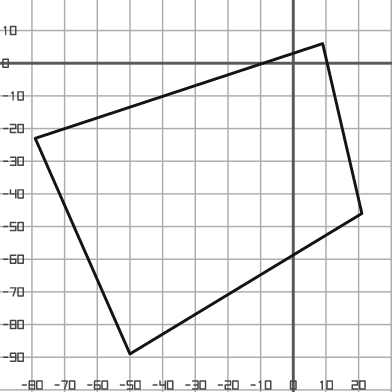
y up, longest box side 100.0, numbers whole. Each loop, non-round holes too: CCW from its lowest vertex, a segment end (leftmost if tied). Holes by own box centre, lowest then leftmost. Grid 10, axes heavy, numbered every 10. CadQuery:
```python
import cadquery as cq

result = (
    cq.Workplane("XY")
    .moveTo(-50.0, -89.0)
    .lineTo(21.0, -46.0)
    .lineTo(9.0, 6.0)
    .lineTo(-79.0, -23.0)
    .close()
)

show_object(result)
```